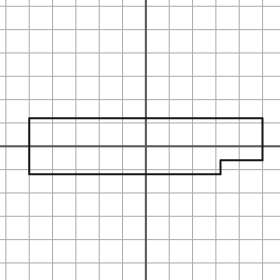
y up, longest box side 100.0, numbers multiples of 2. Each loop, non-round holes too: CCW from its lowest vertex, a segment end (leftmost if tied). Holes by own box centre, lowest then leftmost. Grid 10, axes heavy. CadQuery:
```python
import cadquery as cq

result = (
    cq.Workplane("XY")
    .moveTo(-50.0, -12.0)
    .lineTo(32.0, -12.0)
    .lineTo(32.0, -6.0)
    .lineTo(50.0, -6.0)
    .lineTo(50.0, 12.0)
    .lineTo(-50.0, 12.0)
    .close()
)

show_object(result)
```